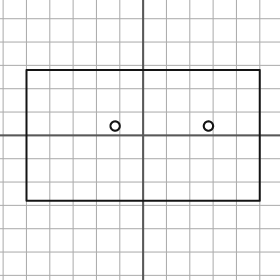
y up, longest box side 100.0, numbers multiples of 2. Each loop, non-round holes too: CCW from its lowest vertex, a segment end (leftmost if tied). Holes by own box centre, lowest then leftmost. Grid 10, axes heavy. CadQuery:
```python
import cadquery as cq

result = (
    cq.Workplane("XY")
    .moveTo(-50.0, -28.0)
    .lineTo(50.0, -28.0)
    .lineTo(50.0, 28.0)
    .lineTo(-50.0, 28.0)
    .close()
    .moveTo(-12.0, 4.0)
    .circle(2.0)
    .moveTo(28.0, 4.0)
    .circle(2.0)
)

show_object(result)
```